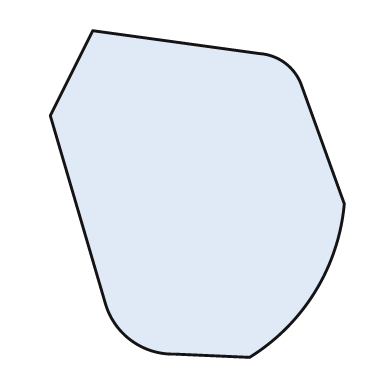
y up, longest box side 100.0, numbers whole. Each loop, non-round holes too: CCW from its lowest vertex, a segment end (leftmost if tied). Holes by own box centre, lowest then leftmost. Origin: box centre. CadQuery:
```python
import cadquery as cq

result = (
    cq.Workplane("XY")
    .moveTo(16.0, -50.0)
    .threePointArc((36.0, -30.0), (45.0, -3.0))
    .lineTo(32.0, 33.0)
    .threePointArc((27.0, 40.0), (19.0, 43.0))
    .lineTo(-32.0, 50.0)
    .lineTo(-45.0, 24.0)
    .lineTo(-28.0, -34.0)
    .threePointArc((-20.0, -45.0), (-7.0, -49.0))
    .close()
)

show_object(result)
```